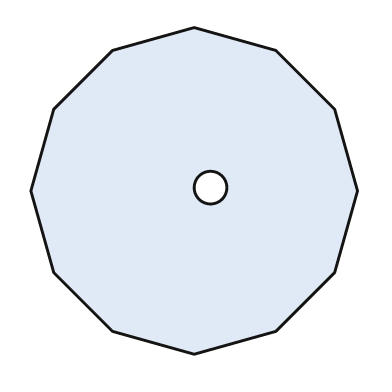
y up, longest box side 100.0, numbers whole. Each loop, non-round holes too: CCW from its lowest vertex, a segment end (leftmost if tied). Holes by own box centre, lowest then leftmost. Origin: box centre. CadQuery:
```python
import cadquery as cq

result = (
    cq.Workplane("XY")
    .moveTo(0.0, -50.0)
    .lineTo(25.0, -43.0)
    .lineTo(43.0, -25.0)
    .lineTo(50.0, 0.0)
    .lineTo(43.0, 25.0)
    .lineTo(25.0, 43.0)
    .lineTo(0.0, 50.0)
    .lineTo(-25.0, 43.0)
    .lineTo(-43.0, 25.0)
    .lineTo(-50.0, 0.0)
    .lineTo(-43.0, -25.0)
    .lineTo(-25.0, -43.0)
    .close()
    .moveTo(5.0, 1.0)
    .circle(5.0)
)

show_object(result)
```